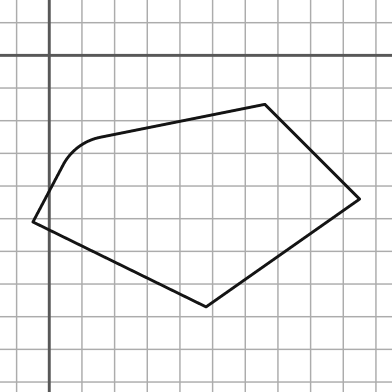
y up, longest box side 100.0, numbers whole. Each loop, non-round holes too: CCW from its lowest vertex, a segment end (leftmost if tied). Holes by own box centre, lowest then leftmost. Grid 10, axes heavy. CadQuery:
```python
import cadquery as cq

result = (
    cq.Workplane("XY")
    .moveTo(48.0, -77.0)
    .lineTo(95.0, -44.0)
    .lineTo(66.0, -15.0)
    .lineTo(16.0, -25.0)
    .threePointArc((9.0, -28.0), (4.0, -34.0))
    .lineTo(-5.0, -51.0)
    .close()
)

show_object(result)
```